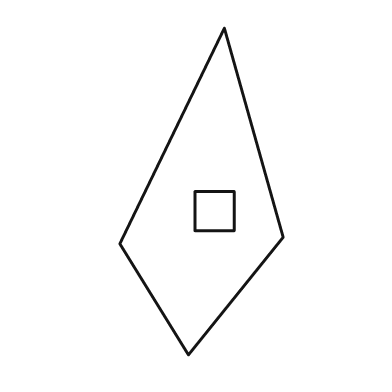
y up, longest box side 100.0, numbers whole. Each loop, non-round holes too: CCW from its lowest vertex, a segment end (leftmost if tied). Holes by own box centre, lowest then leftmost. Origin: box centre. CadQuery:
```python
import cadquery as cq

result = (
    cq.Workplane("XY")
    .moveTo(-4.0, -50.0)
    .lineTo(25.0, -14.0)
    .lineTo(7.0, 50.0)
    .lineTo(-25.0, -16.0)
    .close()
    .moveTo(-2.0, -12.0)
    .lineTo(10.0, -12.0)
    .lineTo(10.0, 0.0)
    .lineTo(-2.0, 0.0)
    .close()
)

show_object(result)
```